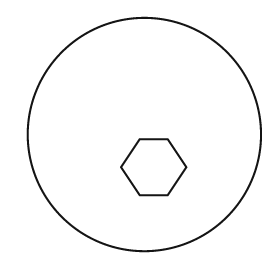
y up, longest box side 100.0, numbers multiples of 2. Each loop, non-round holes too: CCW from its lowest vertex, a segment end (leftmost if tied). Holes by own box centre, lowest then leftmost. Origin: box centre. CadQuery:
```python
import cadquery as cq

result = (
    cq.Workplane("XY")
    .moveTo(0.0, 0.0)
    .circle(50.0)
    .moveTo(-2.0, -26.0)
    .lineTo(10.0, -26.0)
    .lineTo(18.0, -14.0)
    .lineTo(10.0, -2.0)
    .lineTo(-2.0, -2.0)
    .lineTo(-10.0, -14.0)
    .close()
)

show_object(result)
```